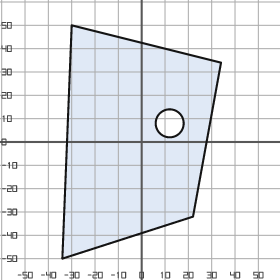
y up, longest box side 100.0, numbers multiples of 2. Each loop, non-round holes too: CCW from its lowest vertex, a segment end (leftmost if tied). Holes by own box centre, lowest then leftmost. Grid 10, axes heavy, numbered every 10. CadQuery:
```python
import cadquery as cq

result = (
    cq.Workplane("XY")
    .moveTo(-34.0, -50.0)
    .lineTo(22.0, -32.0)
    .lineTo(34.0, 34.0)
    .lineTo(-30.0, 50.0)
    .close()
    .moveTo(12.0, 8.0)
    .circle(6.0)
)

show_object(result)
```